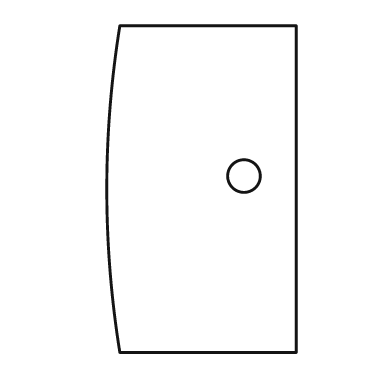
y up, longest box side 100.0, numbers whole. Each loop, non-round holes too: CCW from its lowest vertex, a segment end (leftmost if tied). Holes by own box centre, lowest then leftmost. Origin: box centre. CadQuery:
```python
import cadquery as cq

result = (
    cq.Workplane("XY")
    .moveTo(-25.0, -50.0)
    .lineTo(29.0, -50.0)
    .lineTo(29.0, 50.0)
    .lineTo(-25.0, 50.0)
    .threePointArc((-29.0, 0.0), (-25.0, -50.0))
    .close()
    .moveTo(13.0, 4.0)
    .circle(5.0)
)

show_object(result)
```